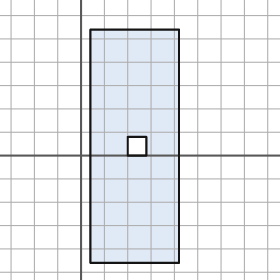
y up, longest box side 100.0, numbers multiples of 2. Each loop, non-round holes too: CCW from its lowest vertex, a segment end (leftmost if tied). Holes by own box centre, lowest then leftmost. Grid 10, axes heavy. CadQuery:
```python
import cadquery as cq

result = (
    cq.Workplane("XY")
    .moveTo(4.0, -46.0)
    .lineTo(42.0, -46.0)
    .lineTo(42.0, 54.0)
    .lineTo(4.0, 54.0)
    .close()
    .moveTo(20.0, 0.0)
    .lineTo(28.0, 0.0)
    .lineTo(28.0, 8.0)
    .lineTo(20.0, 8.0)
    .close()
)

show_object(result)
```